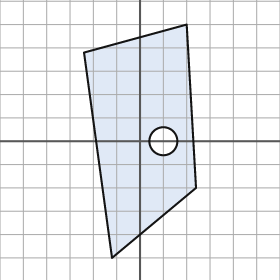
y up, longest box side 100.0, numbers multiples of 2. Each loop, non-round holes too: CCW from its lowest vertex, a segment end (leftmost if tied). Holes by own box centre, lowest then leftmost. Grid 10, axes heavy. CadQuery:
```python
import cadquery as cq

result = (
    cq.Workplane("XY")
    .moveTo(-12.0, -50.0)
    .lineTo(24.0, -20.0)
    .lineTo(20.0, 50.0)
    .lineTo(-24.0, 38.0)
    .close()
    .moveTo(10.0, 0.0)
    .circle(6.0)
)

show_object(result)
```